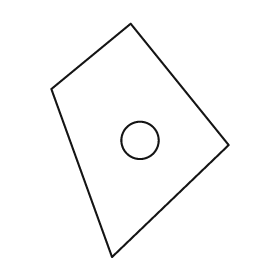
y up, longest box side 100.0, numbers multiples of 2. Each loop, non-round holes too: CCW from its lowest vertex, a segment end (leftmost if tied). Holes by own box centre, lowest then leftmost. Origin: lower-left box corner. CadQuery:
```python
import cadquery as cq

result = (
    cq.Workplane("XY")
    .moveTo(26.0, 0.0)
    .lineTo(76.0, 48.0)
    .lineTo(34.0, 100.0)
    .lineTo(0.0, 72.0)
    .close()
    .moveTo(38.0, 50.0)
    .circle(8.0)
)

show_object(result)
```